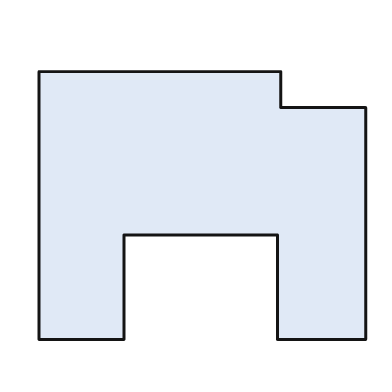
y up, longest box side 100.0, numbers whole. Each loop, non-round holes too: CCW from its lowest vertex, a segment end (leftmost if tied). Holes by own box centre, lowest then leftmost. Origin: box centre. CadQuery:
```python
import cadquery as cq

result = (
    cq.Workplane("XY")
    .moveTo(-50.0, -41.0)
    .lineTo(-24.0, -41.0)
    .lineTo(-24.0, -9.0)
    .lineTo(23.0, -9.0)
    .lineTo(23.0, -41.0)
    .lineTo(50.0, -41.0)
    .lineTo(50.0, 30.0)
    .lineTo(24.0, 30.0)
    .lineTo(24.0, 41.0)
    .lineTo(-50.0, 41.0)
    .close()
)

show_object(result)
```